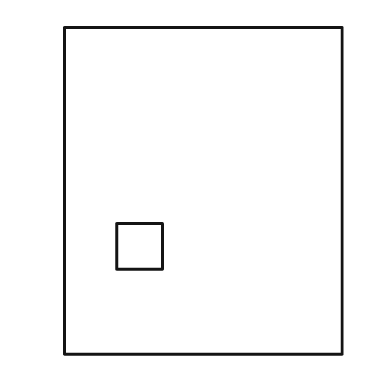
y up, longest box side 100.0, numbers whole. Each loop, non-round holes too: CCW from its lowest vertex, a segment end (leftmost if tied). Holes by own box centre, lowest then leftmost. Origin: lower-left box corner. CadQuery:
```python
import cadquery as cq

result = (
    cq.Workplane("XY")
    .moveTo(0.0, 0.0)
    .lineTo(85.0, 0.0)
    .lineTo(85.0, 100.0)
    .lineTo(0.0, 100.0)
    .close()
    .moveTo(16.0, 26.0)
    .lineTo(30.0, 26.0)
    .lineTo(30.0, 40.0)
    .lineTo(16.0, 40.0)
    .close()
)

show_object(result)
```